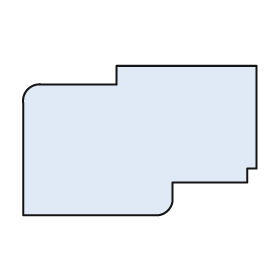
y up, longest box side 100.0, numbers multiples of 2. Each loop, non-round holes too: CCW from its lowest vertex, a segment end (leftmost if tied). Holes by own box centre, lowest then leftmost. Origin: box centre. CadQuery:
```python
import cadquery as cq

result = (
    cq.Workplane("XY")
    .moveTo(-50.0, -32.0)
    .lineTo(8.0, -32.0)
    .threePointArc((12.0, -30.0), (14.0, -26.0))
    .lineTo(14.0, -18.0)
    .lineTo(46.0, -18.0)
    .lineTo(46.0, -12.0)
    .lineTo(50.0, -12.0)
    .lineTo(50.0, 32.0)
    .lineTo(-10.0, 32.0)
    .lineTo(-10.0, 24.0)
    .lineTo(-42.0, 24.0)
    .threePointArc((-48.0, 22.0), (-50.0, 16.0))
    .close()
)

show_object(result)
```